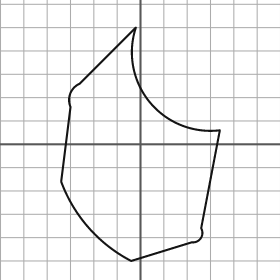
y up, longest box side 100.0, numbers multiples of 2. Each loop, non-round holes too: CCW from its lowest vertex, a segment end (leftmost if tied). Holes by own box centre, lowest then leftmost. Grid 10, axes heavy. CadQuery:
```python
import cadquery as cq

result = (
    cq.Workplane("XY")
    .moveTo(-4.0, -50.0)
    .lineTo(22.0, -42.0)
    .threePointArc((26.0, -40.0), (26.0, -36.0))
    .lineTo(34.0, 6.0)
    .threePointArc((4.0, 18.0), (-2.0, 50.0))
    .lineTo(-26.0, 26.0)
    .threePointArc((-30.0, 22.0), (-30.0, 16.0))
    .lineTo(-34.0, -16.0)
    .threePointArc((-22.0, -36.0), (-4.0, -50.0))
    .close()
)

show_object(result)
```